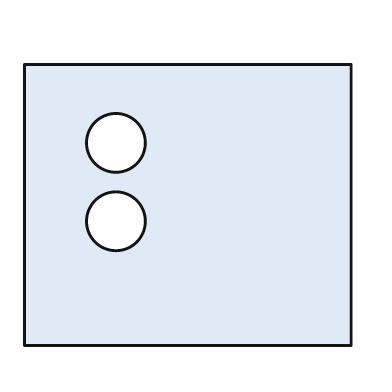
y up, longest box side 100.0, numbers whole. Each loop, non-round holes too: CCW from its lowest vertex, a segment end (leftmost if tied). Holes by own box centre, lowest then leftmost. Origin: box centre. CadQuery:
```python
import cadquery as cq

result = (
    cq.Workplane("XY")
    .moveTo(-50.0, -43.0)
    .lineTo(50.0, -43.0)
    .lineTo(50.0, 43.0)
    .lineTo(-50.0, 43.0)
    .close()
    .moveTo(-22.0, -5.0)
    .circle(9.0)
    .moveTo(-22.0, 19.0)
    .circle(9.0)
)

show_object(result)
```